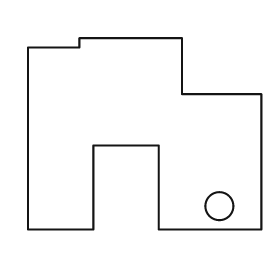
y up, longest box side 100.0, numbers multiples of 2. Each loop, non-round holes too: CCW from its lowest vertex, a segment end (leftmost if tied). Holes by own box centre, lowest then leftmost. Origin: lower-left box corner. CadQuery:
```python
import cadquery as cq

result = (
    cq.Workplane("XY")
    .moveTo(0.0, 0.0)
    .lineTo(28.0, 0.0)
    .lineTo(28.0, 36.0)
    .lineTo(56.0, 36.0)
    .lineTo(56.0, 0.0)
    .lineTo(100.0, 0.0)
    .lineTo(100.0, 58.0)
    .lineTo(66.0, 58.0)
    .lineTo(66.0, 82.0)
    .lineTo(22.0, 82.0)
    .lineTo(22.0, 78.0)
    .lineTo(0.0, 78.0)
    .close()
    .moveTo(82.0, 10.0)
    .circle(6.0)
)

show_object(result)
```